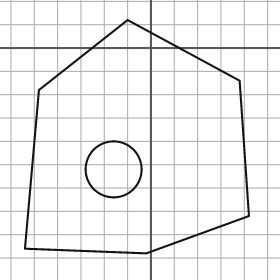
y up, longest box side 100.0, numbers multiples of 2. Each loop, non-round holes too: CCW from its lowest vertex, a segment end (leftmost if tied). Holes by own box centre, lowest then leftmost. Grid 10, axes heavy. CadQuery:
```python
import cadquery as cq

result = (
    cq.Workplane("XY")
    .moveTo(-2.0, -88.0)
    .lineTo(42.0, -72.0)
    .lineTo(38.0, -14.0)
    .lineTo(-10.0, 12.0)
    .lineTo(-48.0, -18.0)
    .lineTo(-54.0, -86.0)
    .close()
    .moveTo(-16.0, -52.0)
    .circle(12.0)
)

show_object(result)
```